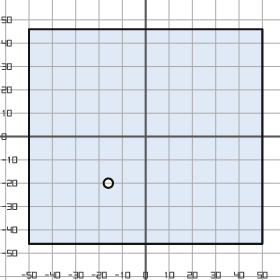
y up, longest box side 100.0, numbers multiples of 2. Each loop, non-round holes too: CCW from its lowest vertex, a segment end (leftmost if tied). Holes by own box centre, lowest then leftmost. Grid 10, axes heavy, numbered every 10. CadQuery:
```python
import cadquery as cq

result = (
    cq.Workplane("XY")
    .moveTo(-50.0, -46.0)
    .lineTo(50.0, -46.0)
    .lineTo(50.0, 46.0)
    .lineTo(-50.0, 46.0)
    .close()
    .moveTo(-16.0, -20.0)
    .circle(2.0)
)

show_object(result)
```